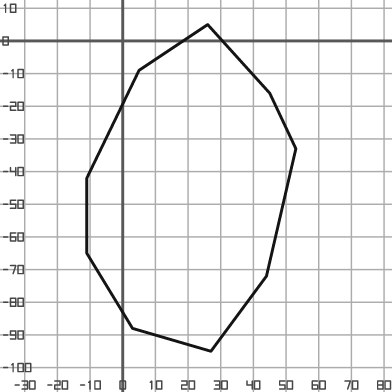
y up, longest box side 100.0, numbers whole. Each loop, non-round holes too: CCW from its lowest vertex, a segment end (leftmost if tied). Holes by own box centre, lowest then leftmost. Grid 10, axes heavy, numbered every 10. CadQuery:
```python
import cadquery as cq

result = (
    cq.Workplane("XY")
    .moveTo(27.0, -95.0)
    .lineTo(44.0, -72.0)
    .lineTo(53.0, -33.0)
    .lineTo(45.0, -16.0)
    .lineTo(26.0, 5.0)
    .lineTo(5.0, -9.0)
    .lineTo(-11.0, -42.0)
    .lineTo(-11.0, -65.0)
    .lineTo(3.0, -88.0)
    .close()
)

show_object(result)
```